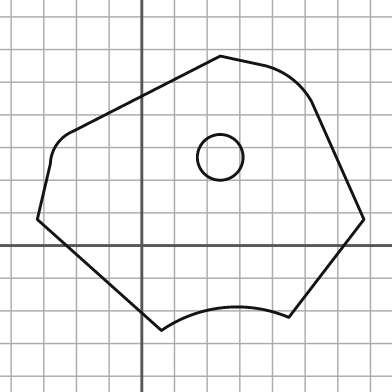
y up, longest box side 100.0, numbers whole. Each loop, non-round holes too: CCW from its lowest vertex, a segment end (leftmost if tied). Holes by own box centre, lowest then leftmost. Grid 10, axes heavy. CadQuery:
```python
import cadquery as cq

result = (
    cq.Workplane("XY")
    .moveTo(6.0, -26.0)
    .threePointArc((25.0, -19.0), (45.0, -22.0))
    .lineTo(68.0, 8.0)
    .lineTo(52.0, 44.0)
    .threePointArc((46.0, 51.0), (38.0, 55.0))
    .lineTo(24.0, 58.0)
    .lineTo(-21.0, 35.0)
    .threePointArc((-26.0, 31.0), (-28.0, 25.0))
    .lineTo(-32.0, 8.0)
    .close()
    .moveTo(24.0, 27.0)
    .circle(7.0)
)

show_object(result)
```